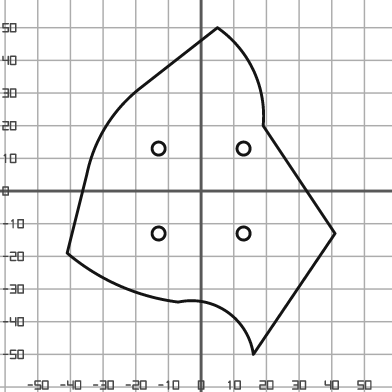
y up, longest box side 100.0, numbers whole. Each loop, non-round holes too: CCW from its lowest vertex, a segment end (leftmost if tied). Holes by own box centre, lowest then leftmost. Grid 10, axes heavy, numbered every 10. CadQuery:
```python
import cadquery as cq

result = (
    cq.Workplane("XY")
    .moveTo(16.0, -50.0)
    .lineTo(41.0, -13.0)
    .lineTo(19.0, 20.0)
    .threePointArc((16.0, 37.0), (5.0, 50.0))
    .lineTo(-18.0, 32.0)
    .threePointArc((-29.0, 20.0), (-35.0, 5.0))
    .lineTo(-41.0, -19.0)
    .threePointArc((-25.0, -29.0), (-7.0, -34.0))
    .threePointArc((8.0, -37.0), (16.0, -50.0))
    .close()
    .moveTo(-13.0, -13.0)
    .circle(2.0)
    .moveTo(13.0, -13.0)
    .circle(2.0)
    .moveTo(-13.0, 13.0)
    .circle(2.0)
    .moveTo(13.0, 13.0)
    .circle(2.0)
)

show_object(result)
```